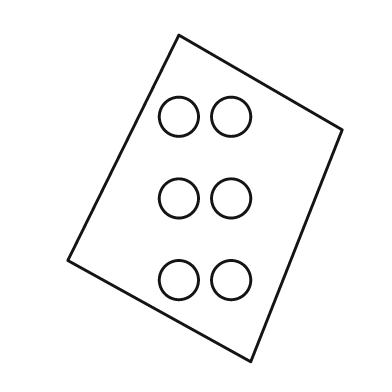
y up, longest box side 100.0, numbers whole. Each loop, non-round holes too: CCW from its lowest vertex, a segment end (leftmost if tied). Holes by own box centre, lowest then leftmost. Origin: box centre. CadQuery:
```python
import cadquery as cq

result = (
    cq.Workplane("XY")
    .moveTo(14.0, -50.0)
    .lineTo(42.0, 21.0)
    .lineTo(-8.0, 50.0)
    .lineTo(-42.0, -19.0)
    .close()
    .moveTo(-8.0, -25.0)
    .circle(6.0)
    .moveTo(8.0, -25.0)
    .circle(6.0)
    .moveTo(-8.0, 0.0)
    .circle(6.0)
    .moveTo(8.0, 0.0)
    .circle(6.0)
    .moveTo(-8.0, 25.0)
    .circle(6.0)
    .moveTo(8.0, 25.0)
    .circle(6.0)
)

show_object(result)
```